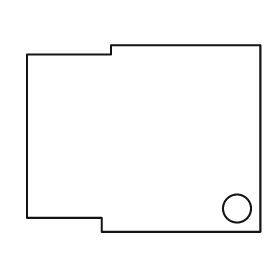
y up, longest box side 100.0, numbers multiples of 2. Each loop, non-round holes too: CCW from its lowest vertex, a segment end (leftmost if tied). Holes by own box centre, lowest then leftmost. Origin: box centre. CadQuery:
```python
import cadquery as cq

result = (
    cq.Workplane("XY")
    .moveTo(-18.0, -40.0)
    .lineTo(50.0, -40.0)
    .lineTo(50.0, 40.0)
    .lineTo(-14.0, 40.0)
    .lineTo(-14.0, 36.0)
    .lineTo(-50.0, 36.0)
    .lineTo(-50.0, -34.0)
    .lineTo(-18.0, -34.0)
    .close()
    .moveTo(40.0, -30.0)
    .circle(6.0)
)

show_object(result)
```